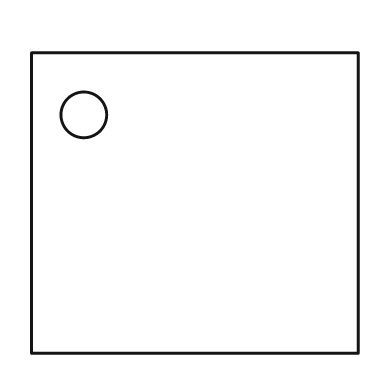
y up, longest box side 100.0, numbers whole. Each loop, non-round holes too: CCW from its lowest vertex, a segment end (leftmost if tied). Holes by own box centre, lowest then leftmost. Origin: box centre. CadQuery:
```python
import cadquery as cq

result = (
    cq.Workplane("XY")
    .moveTo(-50.0, -46.0)
    .lineTo(50.0, -46.0)
    .lineTo(50.0, 46.0)
    .lineTo(-50.0, 46.0)
    .close()
    .moveTo(-34.0, 27.0)
    .circle(7.0)
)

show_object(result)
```